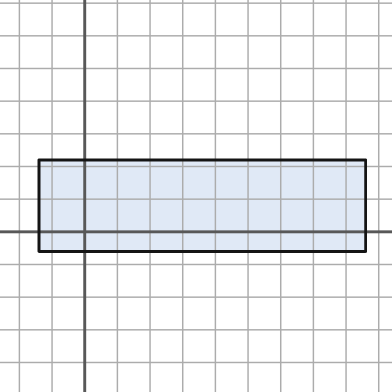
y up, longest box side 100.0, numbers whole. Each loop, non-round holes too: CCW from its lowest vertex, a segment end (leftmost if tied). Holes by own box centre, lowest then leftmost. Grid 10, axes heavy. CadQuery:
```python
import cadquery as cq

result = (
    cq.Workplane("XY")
    .moveTo(-14.0, -6.0)
    .lineTo(86.0, -6.0)
    .lineTo(86.0, 22.0)
    .lineTo(-14.0, 22.0)
    .close()
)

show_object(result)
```